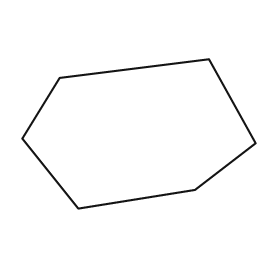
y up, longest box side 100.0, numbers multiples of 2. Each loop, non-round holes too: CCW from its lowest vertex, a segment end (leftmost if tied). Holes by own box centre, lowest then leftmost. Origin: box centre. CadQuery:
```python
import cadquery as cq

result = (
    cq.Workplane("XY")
    .moveTo(-26.0, -32.0)
    .lineTo(24.0, -24.0)
    .lineTo(50.0, -4.0)
    .lineTo(30.0, 32.0)
    .lineTo(-34.0, 24.0)
    .lineTo(-50.0, -2.0)
    .close()
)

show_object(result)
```